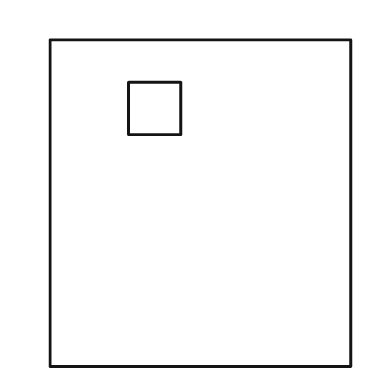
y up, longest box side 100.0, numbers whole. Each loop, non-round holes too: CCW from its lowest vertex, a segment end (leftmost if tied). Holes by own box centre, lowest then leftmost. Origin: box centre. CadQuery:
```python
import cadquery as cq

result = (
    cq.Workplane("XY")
    .moveTo(-46.0, -50.0)
    .lineTo(46.0, -50.0)
    .lineTo(46.0, 50.0)
    .lineTo(-46.0, 50.0)
    .close()
    .moveTo(-22.0, 21.0)
    .lineTo(-6.0, 21.0)
    .lineTo(-6.0, 37.0)
    .lineTo(-22.0, 37.0)
    .close()
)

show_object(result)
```